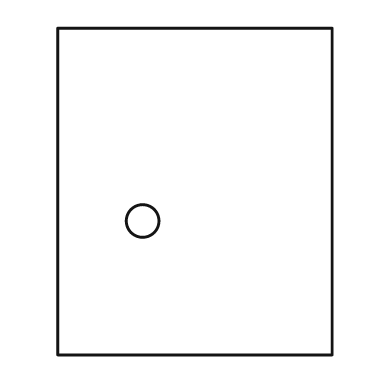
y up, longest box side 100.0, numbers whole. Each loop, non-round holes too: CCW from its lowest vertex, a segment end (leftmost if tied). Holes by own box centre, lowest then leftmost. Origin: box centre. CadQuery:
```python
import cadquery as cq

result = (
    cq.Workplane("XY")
    .moveTo(-42.0, -50.0)
    .lineTo(42.0, -50.0)
    .lineTo(42.0, 50.0)
    .lineTo(-42.0, 50.0)
    .close()
    .moveTo(-16.0, -9.0)
    .circle(5.0)
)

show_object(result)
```